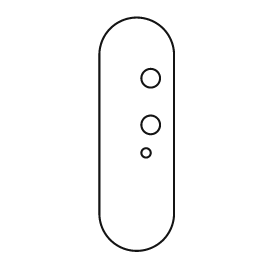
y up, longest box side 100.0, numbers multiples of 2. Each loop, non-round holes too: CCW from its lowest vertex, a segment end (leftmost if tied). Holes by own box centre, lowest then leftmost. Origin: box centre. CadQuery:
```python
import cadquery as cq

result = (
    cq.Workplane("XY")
    .moveTo(-16.0, -34.0)
    .threePointArc((0.0, -50.0), (16.0, -34.0))
    .lineTo(16.0, 34.0)
    .threePointArc((0.0, 50.0), (-16.0, 34.0))
    .close()
    .moveTo(4.0, -8.0)
    .circle(2.0)
    .moveTo(6.0, 4.0)
    .circle(4.0)
    .moveTo(6.0, 24.0)
    .circle(4.0)
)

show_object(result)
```